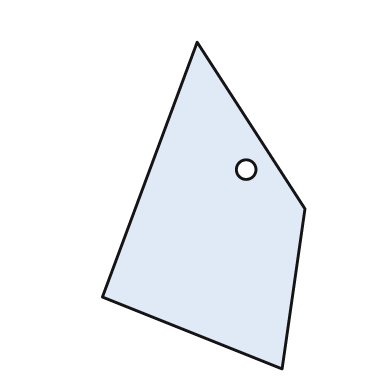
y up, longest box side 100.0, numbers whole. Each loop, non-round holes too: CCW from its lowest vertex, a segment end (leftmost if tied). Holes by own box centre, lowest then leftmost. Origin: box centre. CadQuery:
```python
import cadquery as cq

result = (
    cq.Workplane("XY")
    .moveTo(24.0, -50.0)
    .lineTo(31.0, -1.0)
    .lineTo(-2.0, 50.0)
    .lineTo(-31.0, -28.0)
    .close()
    .moveTo(13.0, 11.0)
    .circle(3.0)
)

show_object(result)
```